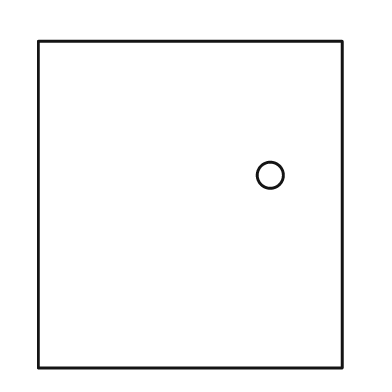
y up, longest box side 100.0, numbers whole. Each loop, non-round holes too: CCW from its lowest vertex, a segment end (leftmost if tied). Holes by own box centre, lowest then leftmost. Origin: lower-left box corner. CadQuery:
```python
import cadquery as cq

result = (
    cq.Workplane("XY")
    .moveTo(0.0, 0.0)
    .lineTo(93.0, 0.0)
    .lineTo(93.0, 100.0)
    .lineTo(0.0, 100.0)
    .close()
    .moveTo(71.0, 59.0)
    .circle(4.0)
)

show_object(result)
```